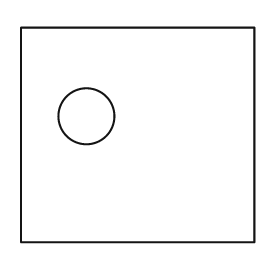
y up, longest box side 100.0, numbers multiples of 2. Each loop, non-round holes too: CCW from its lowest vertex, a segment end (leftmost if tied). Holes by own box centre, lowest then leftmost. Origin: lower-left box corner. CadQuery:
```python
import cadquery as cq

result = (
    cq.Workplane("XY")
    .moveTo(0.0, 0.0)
    .lineTo(100.0, 0.0)
    .lineTo(100.0, 92.0)
    .lineTo(0.0, 92.0)
    .close()
    .moveTo(28.0, 54.0)
    .circle(12.0)
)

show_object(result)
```